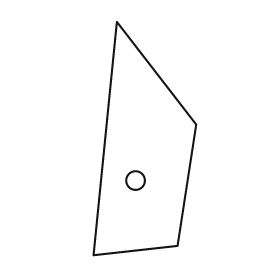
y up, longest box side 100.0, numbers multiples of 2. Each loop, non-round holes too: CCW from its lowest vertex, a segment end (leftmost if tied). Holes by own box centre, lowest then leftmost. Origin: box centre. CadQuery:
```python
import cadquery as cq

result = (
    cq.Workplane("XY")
    .moveTo(-22.0, -50.0)
    .lineTo(14.0, -46.0)
    .lineTo(22.0, 6.0)
    .lineTo(-12.0, 50.0)
    .close()
    .moveTo(-4.0, -18.0)
    .circle(4.0)
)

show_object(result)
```